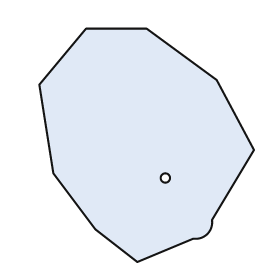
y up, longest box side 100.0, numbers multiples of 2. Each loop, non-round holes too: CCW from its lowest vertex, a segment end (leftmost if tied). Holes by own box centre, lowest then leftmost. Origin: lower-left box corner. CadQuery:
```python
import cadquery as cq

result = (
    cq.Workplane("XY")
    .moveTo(42.0, 0.0)
    .lineTo(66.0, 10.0)
    .threePointArc((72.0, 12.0), (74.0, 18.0))
    .lineTo(92.0, 48.0)
    .lineTo(76.0, 78.0)
    .lineTo(46.0, 100.0)
    .lineTo(20.0, 100.0)
    .lineTo(0.0, 76.0)
    .lineTo(6.0, 38.0)
    .lineTo(24.0, 14.0)
    .close()
    .moveTo(54.0, 36.0)
    .circle(2.0)
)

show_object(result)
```